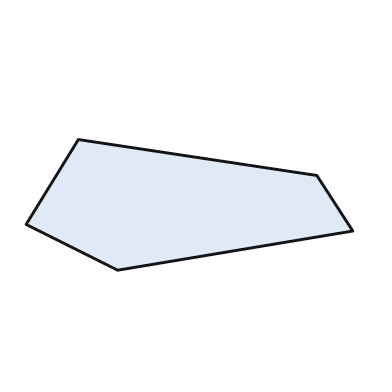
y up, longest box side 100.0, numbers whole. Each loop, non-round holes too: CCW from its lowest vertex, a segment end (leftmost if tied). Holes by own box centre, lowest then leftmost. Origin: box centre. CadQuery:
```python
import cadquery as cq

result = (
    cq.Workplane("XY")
    .moveTo(-22.0, -20.0)
    .lineTo(50.0, -8.0)
    .lineTo(39.0, 9.0)
    .lineTo(-34.0, 20.0)
    .lineTo(-50.0, -6.0)
    .close()
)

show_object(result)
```